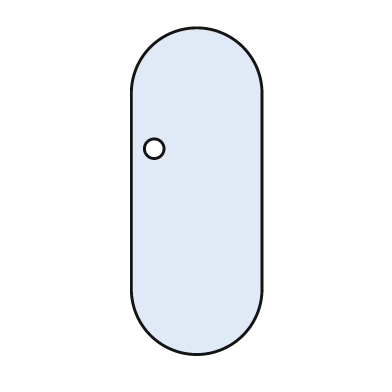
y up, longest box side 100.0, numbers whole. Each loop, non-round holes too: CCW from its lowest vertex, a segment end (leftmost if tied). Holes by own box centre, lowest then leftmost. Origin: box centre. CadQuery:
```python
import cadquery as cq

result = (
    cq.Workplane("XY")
    .moveTo(-20.0, -30.0)
    .threePointArc((0.0, -50.0), (20.0, -30.0))
    .lineTo(20.0, 30.0)
    .threePointArc((0.0, 50.0), (-20.0, 30.0))
    .close()
    .moveTo(-13.0, 13.0)
    .circle(3.0)
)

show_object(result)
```